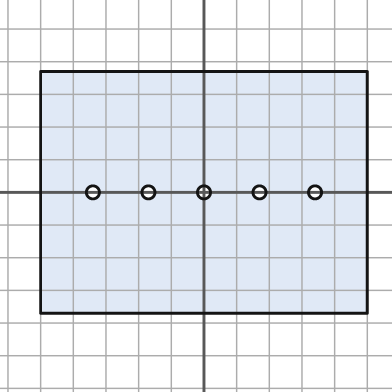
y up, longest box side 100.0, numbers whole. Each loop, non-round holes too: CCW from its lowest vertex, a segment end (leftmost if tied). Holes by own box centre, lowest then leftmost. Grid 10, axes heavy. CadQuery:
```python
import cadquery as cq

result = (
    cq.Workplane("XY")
    .moveTo(-50.0, -37.0)
    .lineTo(50.0, -37.0)
    .lineTo(50.0, 37.0)
    .lineTo(-50.0, 37.0)
    .close()
    .moveTo(-34.0, 0.0)
    .circle(2.0)
    .moveTo(-17.0, 0.0)
    .circle(2.0)
    .moveTo(0.0, 0.0)
    .circle(2.0)
    .moveTo(17.0, 0.0)
    .circle(2.0)
    .moveTo(34.0, 0.0)
    .circle(2.0)
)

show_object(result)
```